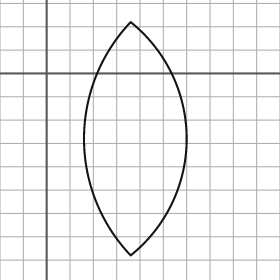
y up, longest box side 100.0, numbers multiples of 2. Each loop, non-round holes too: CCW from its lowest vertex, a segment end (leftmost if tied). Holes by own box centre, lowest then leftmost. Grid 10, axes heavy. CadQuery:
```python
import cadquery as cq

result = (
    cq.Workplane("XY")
    .moveTo(36.0, -78.0)
    .threePointArc((60.0, -28.0), (36.0, 22.0))
    .threePointArc((16.0, -28.0), (36.0, -78.0))
    .close()
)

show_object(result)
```